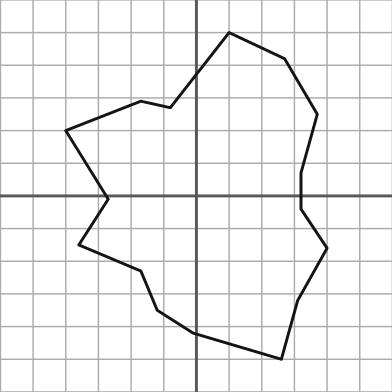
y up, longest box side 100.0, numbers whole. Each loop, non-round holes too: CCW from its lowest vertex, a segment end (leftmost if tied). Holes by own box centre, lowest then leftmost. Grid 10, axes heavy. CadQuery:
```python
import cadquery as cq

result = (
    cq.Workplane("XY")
    .moveTo(26.0, -50.0)
    .lineTo(31.0, -32.0)
    .lineTo(40.0, -16.0)
    .lineTo(32.0, -4.0)
    .lineTo(32.0, 7.0)
    .lineTo(37.0, 25.0)
    .lineTo(27.0, 42.0)
    .lineTo(10.0, 50.0)
    .lineTo(-8.0, 27.0)
    .lineTo(-17.0, 29.0)
    .lineTo(-40.0, 20.0)
    .lineTo(-27.0, -1.0)
    .lineTo(-36.0, -15.0)
    .lineTo(-17.0, -23.0)
    .lineTo(-12.0, -35.0)
    .lineTo(-1.0, -42.0)
    .close()
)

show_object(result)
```